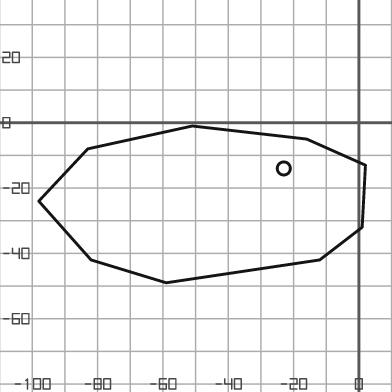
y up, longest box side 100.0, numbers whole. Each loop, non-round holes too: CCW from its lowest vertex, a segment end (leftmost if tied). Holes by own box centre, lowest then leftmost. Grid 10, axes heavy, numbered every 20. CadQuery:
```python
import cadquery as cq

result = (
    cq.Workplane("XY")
    .moveTo(-59.0, -49.0)
    .lineTo(-12.0, -42.0)
    .lineTo(1.0, -32.0)
    .lineTo(2.0, -13.0)
    .lineTo(-16.0, -5.0)
    .lineTo(-51.0, -1.0)
    .lineTo(-83.0, -8.0)
    .lineTo(-98.0, -24.0)
    .lineTo(-82.0, -42.0)
    .close()
    .moveTo(-23.0, -14.0)
    .circle(2.0)
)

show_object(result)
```